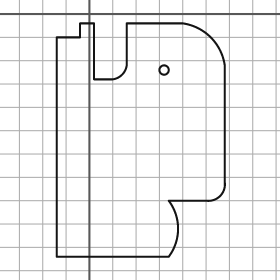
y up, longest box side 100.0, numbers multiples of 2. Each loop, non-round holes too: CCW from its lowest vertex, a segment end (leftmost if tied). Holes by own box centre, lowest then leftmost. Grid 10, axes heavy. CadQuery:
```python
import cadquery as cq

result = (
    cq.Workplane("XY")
    .moveTo(-14.0, -104.0)
    .lineTo(34.0, -104.0)
    .threePointArc((38.0, -92.0), (34.0, -80.0))
    .lineTo(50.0, -80.0)
    .threePointArc((56.0, -78.0), (58.0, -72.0))
    .lineTo(58.0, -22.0)
    .threePointArc((52.0, -10.0), (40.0, -4.0))
    .lineTo(16.0, -4.0)
    .lineTo(16.0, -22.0)
    .threePointArc((14.0, -26.0), (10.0, -28.0))
    .lineTo(2.0, -28.0)
    .lineTo(2.0, -4.0)
    .lineTo(-4.0, -4.0)
    .lineTo(-4.0, -10.0)
    .lineTo(-14.0, -10.0)
    .close()
    .moveTo(32.0, -24.0)
    .circle(2.0)
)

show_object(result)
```